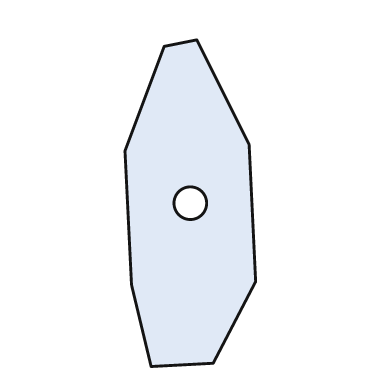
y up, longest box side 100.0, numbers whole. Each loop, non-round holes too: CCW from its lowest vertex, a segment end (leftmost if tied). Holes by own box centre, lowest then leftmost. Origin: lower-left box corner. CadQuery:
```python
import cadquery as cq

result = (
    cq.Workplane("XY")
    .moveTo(8.0, 0.0)
    .lineTo(27.0, 1.0)
    .lineTo(40.0, 26.0)
    .lineTo(38.0, 68.0)
    .lineTo(22.0, 100.0)
    .lineTo(12.0, 98.0)
    .lineTo(0.0, 66.0)
    .lineTo(2.0, 25.0)
    .close()
    .moveTo(20.0, 50.0)
    .circle(5.0)
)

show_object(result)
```